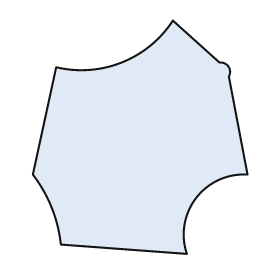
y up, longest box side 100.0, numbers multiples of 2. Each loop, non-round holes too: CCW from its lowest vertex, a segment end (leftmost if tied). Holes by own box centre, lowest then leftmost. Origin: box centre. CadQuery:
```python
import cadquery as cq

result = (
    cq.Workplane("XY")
    .moveTo(20.0, -50.0)
    .threePointArc((24.0, -26.0), (46.0, -16.0))
    .lineTo(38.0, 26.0)
    .threePointArc((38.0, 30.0), (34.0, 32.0))
    .lineTo(14.0, 50.0)
    .threePointArc((-8.0, 32.0), (-36.0, 30.0))
    .lineTo(-46.0, -16.0)
    .threePointArc((-38.0, -30.0), (-34.0, -46.0))
    .close()
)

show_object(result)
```